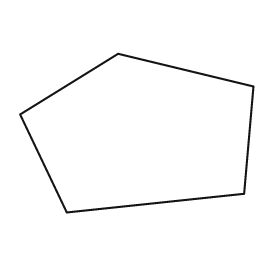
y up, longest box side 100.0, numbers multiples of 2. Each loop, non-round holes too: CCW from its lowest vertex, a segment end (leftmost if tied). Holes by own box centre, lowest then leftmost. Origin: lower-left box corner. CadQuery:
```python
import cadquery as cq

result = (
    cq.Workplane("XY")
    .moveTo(20.0, 0.0)
    .lineTo(96.0, 8.0)
    .lineTo(100.0, 54.0)
    .lineTo(42.0, 68.0)
    .lineTo(0.0, 42.0)
    .close()
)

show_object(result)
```